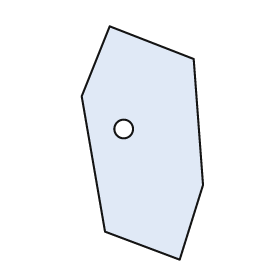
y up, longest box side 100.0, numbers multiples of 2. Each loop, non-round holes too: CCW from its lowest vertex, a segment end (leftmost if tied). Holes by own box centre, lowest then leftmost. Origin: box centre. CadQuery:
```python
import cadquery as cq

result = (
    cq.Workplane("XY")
    .moveTo(16.0, -50.0)
    .lineTo(26.0, -18.0)
    .lineTo(22.0, 36.0)
    .lineTo(-14.0, 50.0)
    .lineTo(-26.0, 20.0)
    .lineTo(-16.0, -38.0)
    .close()
    .moveTo(-8.0, 6.0)
    .circle(4.0)
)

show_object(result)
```